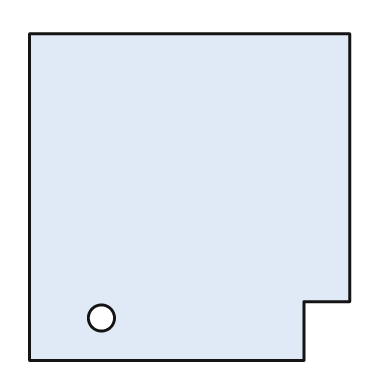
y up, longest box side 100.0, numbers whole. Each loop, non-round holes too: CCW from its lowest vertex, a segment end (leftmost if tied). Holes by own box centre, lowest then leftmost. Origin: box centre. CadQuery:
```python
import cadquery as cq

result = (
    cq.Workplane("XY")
    .moveTo(-49.0, -50.0)
    .lineTo(35.0, -50.0)
    .lineTo(35.0, -32.0)
    .lineTo(49.0, -32.0)
    .lineTo(49.0, 50.0)
    .lineTo(-49.0, 50.0)
    .close()
    .moveTo(-27.0, -37.0)
    .circle(4.0)
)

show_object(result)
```